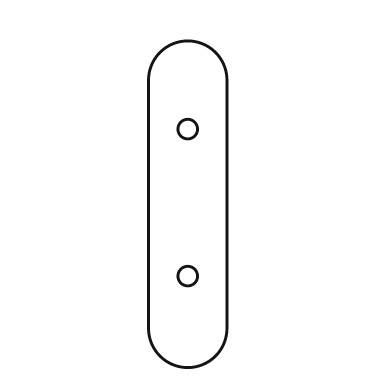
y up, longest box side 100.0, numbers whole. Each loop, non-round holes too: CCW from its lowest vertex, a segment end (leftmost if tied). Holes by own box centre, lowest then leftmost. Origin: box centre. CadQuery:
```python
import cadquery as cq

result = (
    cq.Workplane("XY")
    .moveTo(-12.0, -38.0)
    .threePointArc((0.0, -50.0), (12.0, -38.0))
    .lineTo(12.0, 38.0)
    .threePointArc((0.0, 50.0), (-12.0, 38.0))
    .close()
    .moveTo(0.0, -22.0)
    .circle(3.0)
    .moveTo(0.0, 23.0)
    .circle(3.0)
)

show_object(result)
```